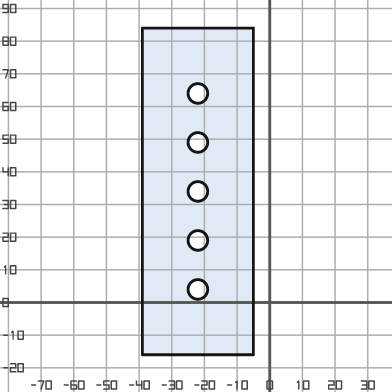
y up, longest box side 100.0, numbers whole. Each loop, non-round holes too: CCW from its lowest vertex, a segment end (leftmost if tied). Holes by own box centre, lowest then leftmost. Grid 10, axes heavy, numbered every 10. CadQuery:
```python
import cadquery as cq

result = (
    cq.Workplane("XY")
    .moveTo(-39.0, -16.0)
    .lineTo(-5.0, -16.0)
    .lineTo(-5.0, 84.0)
    .lineTo(-39.0, 84.0)
    .close()
    .moveTo(-22.0, 4.0)
    .circle(3.0)
    .moveTo(-22.0, 19.0)
    .circle(3.0)
    .moveTo(-22.0, 34.0)
    .circle(3.0)
    .moveTo(-22.0, 49.0)
    .circle(3.0)
    .moveTo(-22.0, 64.0)
    .circle(3.0)
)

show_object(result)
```